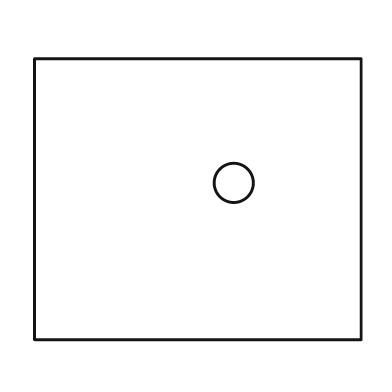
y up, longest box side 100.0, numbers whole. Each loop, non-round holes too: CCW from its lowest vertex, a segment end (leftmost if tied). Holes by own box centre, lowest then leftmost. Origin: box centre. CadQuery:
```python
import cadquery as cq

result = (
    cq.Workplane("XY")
    .moveTo(-50.0, -43.0)
    .lineTo(50.0, -43.0)
    .lineTo(50.0, 43.0)
    .lineTo(-50.0, 43.0)
    .close()
    .moveTo(11.0, 5.0)
    .circle(6.0)
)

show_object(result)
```